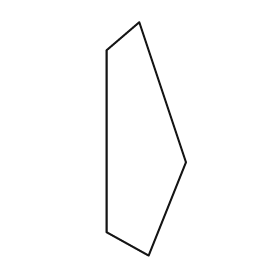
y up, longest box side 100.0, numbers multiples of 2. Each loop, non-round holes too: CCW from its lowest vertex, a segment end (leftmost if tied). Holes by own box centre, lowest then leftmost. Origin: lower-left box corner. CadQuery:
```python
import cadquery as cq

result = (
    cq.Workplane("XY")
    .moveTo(18.0, 0.0)
    .lineTo(34.0, 40.0)
    .lineTo(14.0, 100.0)
    .lineTo(0.0, 88.0)
    .lineTo(0.0, 10.0)
    .close()
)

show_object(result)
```